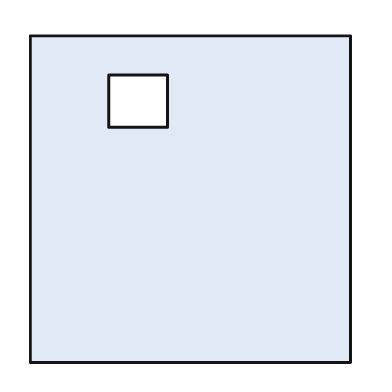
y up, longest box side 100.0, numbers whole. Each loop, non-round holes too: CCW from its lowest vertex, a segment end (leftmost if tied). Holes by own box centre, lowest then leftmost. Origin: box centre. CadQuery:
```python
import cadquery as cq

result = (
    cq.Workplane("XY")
    .moveTo(-49.0, -50.0)
    .lineTo(49.0, -50.0)
    .lineTo(49.0, 50.0)
    .lineTo(-49.0, 50.0)
    .close()
    .moveTo(-25.0, 22.0)
    .lineTo(-7.0, 22.0)
    .lineTo(-7.0, 38.0)
    .lineTo(-25.0, 38.0)
    .close()
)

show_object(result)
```